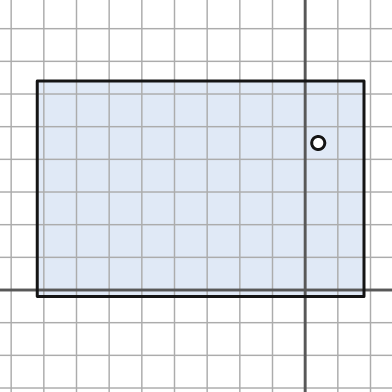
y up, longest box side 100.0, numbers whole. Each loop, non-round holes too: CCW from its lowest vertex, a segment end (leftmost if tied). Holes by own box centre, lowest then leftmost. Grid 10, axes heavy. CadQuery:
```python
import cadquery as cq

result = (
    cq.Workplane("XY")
    .moveTo(-82.0, -2.0)
    .lineTo(18.0, -2.0)
    .lineTo(18.0, 64.0)
    .lineTo(-82.0, 64.0)
    .close()
    .moveTo(4.0, 45.0)
    .circle(2.0)
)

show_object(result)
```